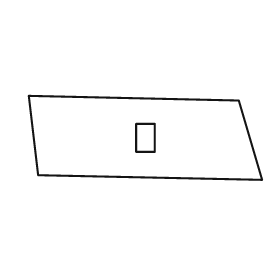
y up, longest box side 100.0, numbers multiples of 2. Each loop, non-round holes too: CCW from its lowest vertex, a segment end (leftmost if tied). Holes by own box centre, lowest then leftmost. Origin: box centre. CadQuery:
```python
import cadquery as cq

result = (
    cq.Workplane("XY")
    .moveTo(50.0, -18.0)
    .lineTo(40.0, 16.0)
    .lineTo(-50.0, 18.0)
    .lineTo(-46.0, -16.0)
    .close()
    .moveTo(-4.0, -6.0)
    .lineTo(4.0, -6.0)
    .lineTo(4.0, 6.0)
    .lineTo(-4.0, 6.0)
    .close()
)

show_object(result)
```